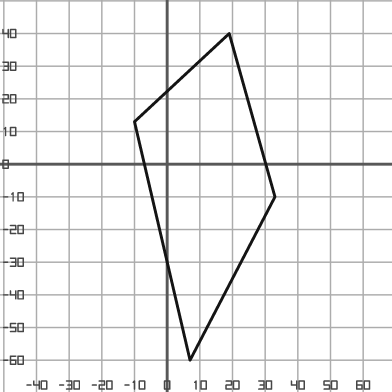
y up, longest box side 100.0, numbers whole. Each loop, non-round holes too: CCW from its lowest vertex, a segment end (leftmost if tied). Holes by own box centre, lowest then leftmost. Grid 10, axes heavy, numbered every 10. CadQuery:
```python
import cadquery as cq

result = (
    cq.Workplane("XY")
    .moveTo(7.0, -60.0)
    .lineTo(33.0, -10.0)
    .lineTo(19.0, 40.0)
    .lineTo(-10.0, 13.0)
    .close()
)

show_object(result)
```